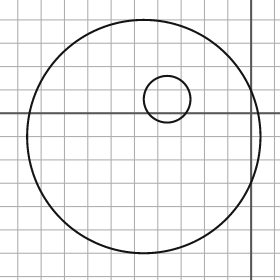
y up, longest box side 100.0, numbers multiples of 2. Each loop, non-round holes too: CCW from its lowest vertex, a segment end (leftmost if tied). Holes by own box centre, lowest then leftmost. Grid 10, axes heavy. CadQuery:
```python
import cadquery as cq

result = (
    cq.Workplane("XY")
    .moveTo(-46.0, -10.0)
    .circle(50.0)
    .moveTo(-36.0, 6.0)
    .circle(10.0)
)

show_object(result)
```